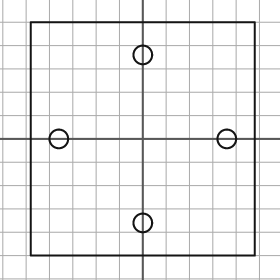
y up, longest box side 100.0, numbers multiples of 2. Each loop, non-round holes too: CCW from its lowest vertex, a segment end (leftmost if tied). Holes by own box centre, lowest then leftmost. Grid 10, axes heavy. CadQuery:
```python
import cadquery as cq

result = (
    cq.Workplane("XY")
    .moveTo(-48.0, -50.0)
    .lineTo(48.0, -50.0)
    .lineTo(48.0, 50.0)
    .lineTo(-48.0, 50.0)
    .close()
    .moveTo(0.0, -36.0)
    .circle(4.0)
    .moveTo(-36.0, 0.0)
    .circle(4.0)
    .moveTo(36.0, 0.0)
    .circle(4.0)
    .moveTo(0.0, 36.0)
    .circle(4.0)
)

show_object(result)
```